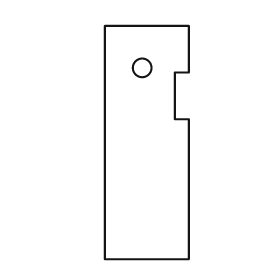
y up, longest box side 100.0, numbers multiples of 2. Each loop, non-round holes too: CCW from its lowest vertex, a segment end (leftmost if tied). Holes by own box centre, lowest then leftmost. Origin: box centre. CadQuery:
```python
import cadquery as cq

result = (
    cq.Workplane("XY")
    .moveTo(-18.0, -50.0)
    .lineTo(18.0, -50.0)
    .lineTo(18.0, 10.0)
    .lineTo(12.0, 10.0)
    .lineTo(12.0, 30.0)
    .lineTo(18.0, 30.0)
    .lineTo(18.0, 50.0)
    .lineTo(-18.0, 50.0)
    .close()
    .moveTo(-2.0, 32.0)
    .circle(4.0)
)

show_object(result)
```